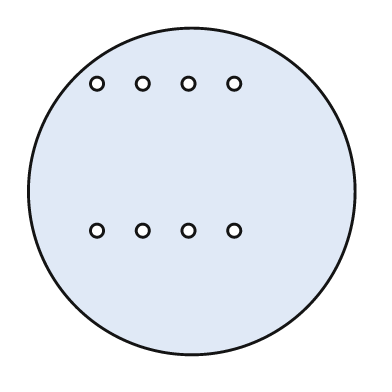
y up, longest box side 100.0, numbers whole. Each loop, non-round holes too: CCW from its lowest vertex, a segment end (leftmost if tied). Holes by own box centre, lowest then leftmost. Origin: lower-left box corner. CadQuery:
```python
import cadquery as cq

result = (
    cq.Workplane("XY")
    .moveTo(50.0, 50.0)
    .circle(50.0)
    .moveTo(21.0, 38.0)
    .circle(2.0)
    .moveTo(35.0, 38.0)
    .circle(2.0)
    .moveTo(49.0, 38.0)
    .circle(2.0)
    .moveTo(63.0, 38.0)
    .circle(2.0)
    .moveTo(21.0, 83.0)
    .circle(2.0)
    .moveTo(35.0, 83.0)
    .circle(2.0)
    .moveTo(49.0, 83.0)
    .circle(2.0)
    .moveTo(63.0, 83.0)
    .circle(2.0)
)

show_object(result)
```